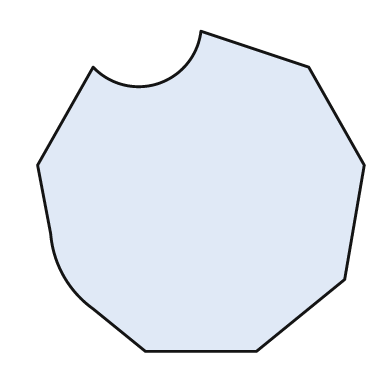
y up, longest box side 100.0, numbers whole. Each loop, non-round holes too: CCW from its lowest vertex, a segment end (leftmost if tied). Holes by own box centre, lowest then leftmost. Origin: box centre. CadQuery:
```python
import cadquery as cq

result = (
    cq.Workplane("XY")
    .moveTo(-17.0, -49.0)
    .lineTo(17.0, -49.0)
    .lineTo(44.0, -27.0)
    .lineTo(50.0, 8.0)
    .lineTo(33.0, 38.0)
    .lineTo(0.0, 49.0)
    .threePointArc((-13.0, 33.0), (-33.0, 38.0))
    .lineTo(-50.0, 8.0)
    .lineTo(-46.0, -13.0)
    .threePointArc((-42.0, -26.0), (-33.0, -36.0))
    .close()
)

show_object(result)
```